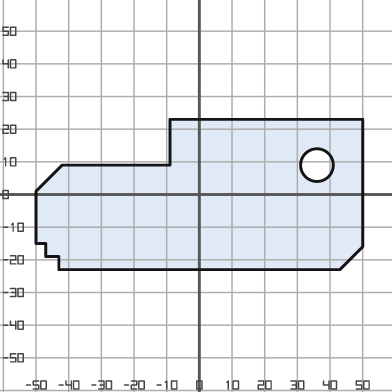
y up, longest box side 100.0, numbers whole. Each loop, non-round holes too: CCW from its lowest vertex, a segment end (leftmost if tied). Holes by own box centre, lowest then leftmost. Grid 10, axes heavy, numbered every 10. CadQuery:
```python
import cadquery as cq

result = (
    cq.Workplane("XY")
    .moveTo(-43.0, -23.0)
    .lineTo(43.0, -23.0)
    .lineTo(50.0, -16.0)
    .lineTo(50.0, 23.0)
    .lineTo(-9.0, 23.0)
    .lineTo(-9.0, 9.0)
    .lineTo(-42.0, 9.0)
    .lineTo(-50.0, 1.0)
    .lineTo(-50.0, -15.0)
    .lineTo(-47.0, -15.0)
    .lineTo(-47.0, -19.0)
    .lineTo(-43.0, -19.0)
    .close()
    .moveTo(36.0, 9.0)
    .circle(5.0)
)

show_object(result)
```